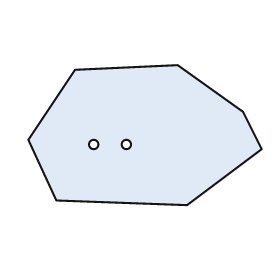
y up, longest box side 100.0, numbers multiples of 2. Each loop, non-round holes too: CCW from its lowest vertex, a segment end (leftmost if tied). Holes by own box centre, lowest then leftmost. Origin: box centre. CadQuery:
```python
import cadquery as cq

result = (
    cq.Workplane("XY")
    .moveTo(18.0, -30.0)
    .lineTo(50.0, -6.0)
    .lineTo(42.0, 10.0)
    .lineTo(14.0, 30.0)
    .lineTo(-30.0, 28.0)
    .lineTo(-50.0, -2.0)
    .lineTo(-38.0, -28.0)
    .close()
    .moveTo(-22.0, -4.0)
    .circle(2.0)
    .moveTo(-8.0, -4.0)
    .circle(2.0)
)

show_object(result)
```